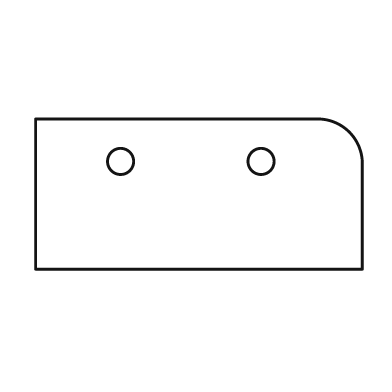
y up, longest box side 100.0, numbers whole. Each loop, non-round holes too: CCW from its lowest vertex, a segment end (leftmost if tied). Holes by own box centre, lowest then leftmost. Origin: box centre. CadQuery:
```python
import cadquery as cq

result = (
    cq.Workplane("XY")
    .moveTo(-50.0, -23.0)
    .lineTo(50.0, -23.0)
    .lineTo(50.0, 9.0)
    .threePointArc((46.0, 19.0), (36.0, 23.0))
    .lineTo(-50.0, 23.0)
    .close()
    .moveTo(-24.0, 10.0)
    .circle(4.0)
    .moveTo(19.0, 10.0)
    .circle(4.0)
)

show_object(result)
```